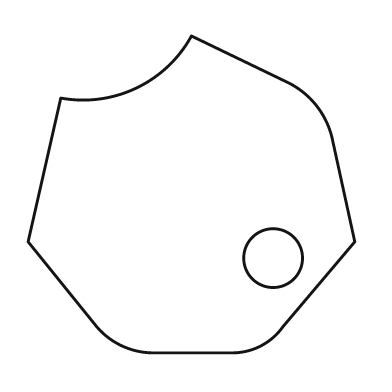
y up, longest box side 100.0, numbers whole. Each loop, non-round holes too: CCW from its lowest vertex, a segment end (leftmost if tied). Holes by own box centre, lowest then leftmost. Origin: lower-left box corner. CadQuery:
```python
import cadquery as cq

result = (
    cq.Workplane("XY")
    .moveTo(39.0, 0.0)
    .lineTo(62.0, 0.0)
    .threePointArc((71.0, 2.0), (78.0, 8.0))
    .lineTo(100.0, 34.0)
    .lineTo(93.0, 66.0)
    .threePointArc((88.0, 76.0), (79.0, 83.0))
    .lineTo(50.0, 97.0)
    .threePointArc((33.0, 81.0), (10.0, 78.0))
    .lineTo(0.0, 34.0)
    .lineTo(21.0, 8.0)
    .threePointArc((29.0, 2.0), (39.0, 0.0))
    .close()
    .moveTo(75.0, 29.0)
    .circle(9.0)
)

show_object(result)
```